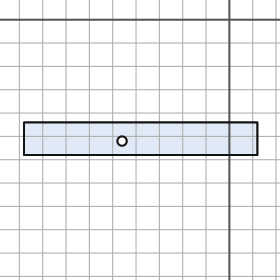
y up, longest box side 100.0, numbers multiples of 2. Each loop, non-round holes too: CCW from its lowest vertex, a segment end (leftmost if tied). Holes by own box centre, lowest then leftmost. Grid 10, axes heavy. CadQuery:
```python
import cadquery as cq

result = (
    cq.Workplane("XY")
    .moveTo(-88.0, -58.0)
    .lineTo(12.0, -58.0)
    .lineTo(12.0, -44.0)
    .lineTo(-88.0, -44.0)
    .close()
    .moveTo(-46.0, -52.0)
    .circle(2.0)
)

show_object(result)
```